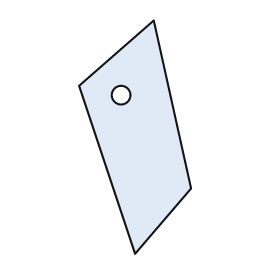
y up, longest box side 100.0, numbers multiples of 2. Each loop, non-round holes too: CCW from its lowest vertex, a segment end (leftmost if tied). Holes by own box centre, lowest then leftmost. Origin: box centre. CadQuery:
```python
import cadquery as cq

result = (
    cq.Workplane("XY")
    .moveTo(0.0, -50.0)
    .lineTo(24.0, -22.0)
    .lineTo(8.0, 50.0)
    .lineTo(-24.0, 22.0)
    .close()
    .moveTo(-6.0, 18.0)
    .circle(4.0)
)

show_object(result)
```